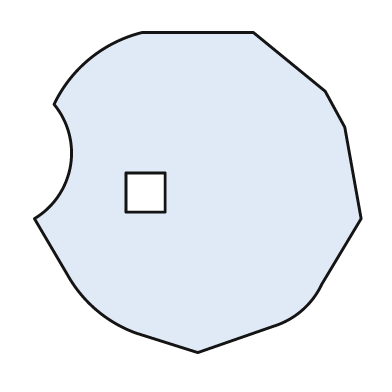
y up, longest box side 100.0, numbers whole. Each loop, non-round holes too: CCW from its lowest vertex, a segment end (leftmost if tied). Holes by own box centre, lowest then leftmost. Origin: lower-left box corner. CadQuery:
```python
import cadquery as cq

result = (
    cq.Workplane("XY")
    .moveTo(50.0, 0.0)
    .lineTo(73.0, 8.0)
    .threePointArc((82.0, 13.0), (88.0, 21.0))
    .lineTo(100.0, 41.0)
    .lineTo(95.0, 69.0)
    .lineTo(89.0, 80.0)
    .lineTo(67.0, 98.0)
    .lineTo(33.0, 98.0)
    .threePointArc((17.0, 90.0), (6.0, 76.0))
    .threePointArc((11.0, 57.0), (0.0, 41.0))
    .lineTo(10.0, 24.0)
    .threePointArc((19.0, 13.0), (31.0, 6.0))
    .close()
    .moveTo(28.0, 43.0)
    .lineTo(40.0, 43.0)
    .lineTo(40.0, 55.0)
    .lineTo(28.0, 55.0)
    .close()
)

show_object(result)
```